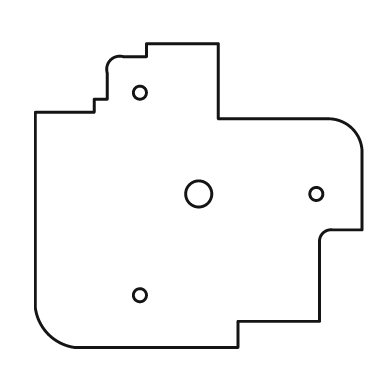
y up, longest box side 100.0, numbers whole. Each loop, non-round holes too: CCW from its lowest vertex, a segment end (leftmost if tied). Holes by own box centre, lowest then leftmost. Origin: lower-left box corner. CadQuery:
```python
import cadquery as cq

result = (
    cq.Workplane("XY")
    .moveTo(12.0, 0.0)
    .lineTo(62.0, 0.0)
    .lineTo(62.0, 8.0)
    .lineTo(87.0, 8.0)
    .lineTo(87.0, 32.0)
    .threePointArc((88.0, 35.0), (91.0, 36.0))
    .lineTo(100.0, 36.0)
    .lineTo(100.0, 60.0)
    .threePointArc((97.0, 67.0), (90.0, 70.0))
    .lineTo(56.0, 70.0)
    .lineTo(56.0, 93.0)
    .lineTo(34.0, 93.0)
    .lineTo(34.0, 89.0)
    .lineTo(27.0, 89.0)
    .threePointArc((23.0, 88.0), (22.0, 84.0))
    .lineTo(22.0, 76.0)
    .lineTo(18.0, 76.0)
    .lineTo(18.0, 72.0)
    .lineTo(0.0, 72.0)
    .lineTo(0.0, 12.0)
    .threePointArc((4.0, 4.0), (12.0, 0.0))
    .close()
    .moveTo(32.0, 16.0)
    .circle(2.0)
    .moveTo(50.0, 47.0)
    .circle(4.0)
    .moveTo(86.0, 47.0)
    .circle(2.0)
    .moveTo(32.0, 78.0)
    .circle(2.0)
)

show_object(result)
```